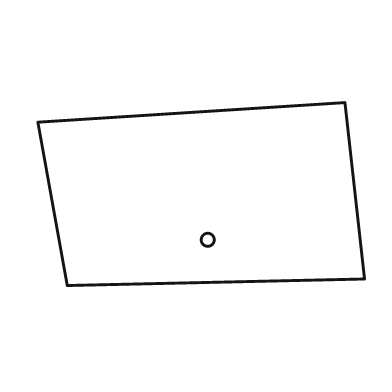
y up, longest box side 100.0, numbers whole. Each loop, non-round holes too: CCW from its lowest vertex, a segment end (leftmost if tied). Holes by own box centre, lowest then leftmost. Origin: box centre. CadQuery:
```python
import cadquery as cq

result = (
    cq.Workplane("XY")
    .moveTo(-41.0, -28.0)
    .lineTo(50.0, -26.0)
    .lineTo(44.0, 28.0)
    .lineTo(-50.0, 22.0)
    .close()
    .moveTo(2.0, -14.0)
    .circle(2.0)
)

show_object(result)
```